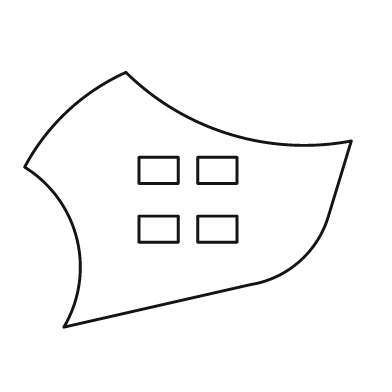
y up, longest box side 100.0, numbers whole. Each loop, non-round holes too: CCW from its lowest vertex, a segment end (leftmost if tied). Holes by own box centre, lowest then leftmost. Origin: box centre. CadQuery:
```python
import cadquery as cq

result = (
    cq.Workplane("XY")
    .moveTo(-38.0, -39.0)
    .lineTo(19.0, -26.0)
    .threePointArc((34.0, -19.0), (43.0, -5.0))
    .lineTo(50.0, 18.0)
    .threePointArc((13.0, 20.0), (-19.0, 39.0))
    .threePointArc((-37.0, 27.0), (-50.0, 10.0))
    .threePointArc((-34.0, -12.0), (-38.0, -39.0))
    .close()
    .moveTo(-15.0, -13.0)
    .lineTo(-3.0, -13.0)
    .lineTo(-3.0, -5.0)
    .lineTo(-15.0, -5.0)
    .close()
    .moveTo(3.0, -13.0)
    .lineTo(15.0, -13.0)
    .lineTo(15.0, -5.0)
    .lineTo(3.0, -5.0)
    .close()
    .moveTo(-15.0, 5.0)
    .lineTo(-3.0, 5.0)
    .lineTo(-3.0, 13.0)
    .lineTo(-15.0, 13.0)
    .close()
    .moveTo(3.0, 5.0)
    .lineTo(15.0, 5.0)
    .lineTo(15.0, 13.0)
    .lineTo(3.0, 13.0)
    .close()
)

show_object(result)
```